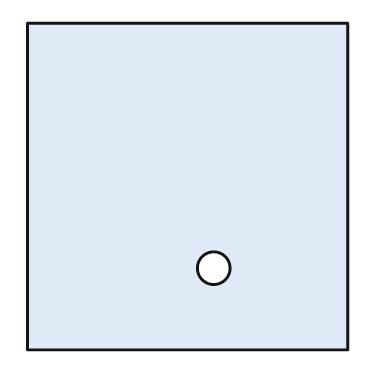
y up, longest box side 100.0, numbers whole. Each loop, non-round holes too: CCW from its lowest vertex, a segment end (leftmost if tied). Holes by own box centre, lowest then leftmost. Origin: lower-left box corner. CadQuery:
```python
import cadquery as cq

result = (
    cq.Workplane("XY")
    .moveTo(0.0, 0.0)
    .lineTo(98.0, 0.0)
    .lineTo(98.0, 100.0)
    .lineTo(0.0, 100.0)
    .close()
    .moveTo(57.0, 25.0)
    .circle(5.0)
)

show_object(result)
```